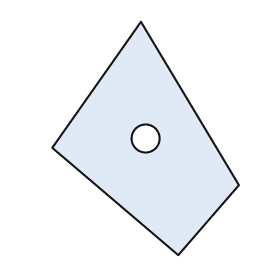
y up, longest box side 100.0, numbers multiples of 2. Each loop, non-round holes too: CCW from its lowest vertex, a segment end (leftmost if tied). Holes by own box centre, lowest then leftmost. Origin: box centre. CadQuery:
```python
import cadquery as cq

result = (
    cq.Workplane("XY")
    .moveTo(14.0, -50.0)
    .lineTo(40.0, -20.0)
    .lineTo(-2.0, 50.0)
    .lineTo(-40.0, -4.0)
    .close()
    .moveTo(0.0, 0.0)
    .circle(6.0)
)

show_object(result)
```